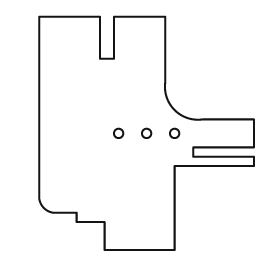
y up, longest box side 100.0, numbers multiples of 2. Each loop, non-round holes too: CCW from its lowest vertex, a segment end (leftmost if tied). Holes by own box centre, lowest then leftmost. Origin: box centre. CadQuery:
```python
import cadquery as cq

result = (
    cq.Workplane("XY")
    .moveTo(-18.0, -50.0)
    .lineTo(12.0, -50.0)
    .lineTo(12.0, -14.0)
    .lineTo(46.0, -14.0)
    .lineTo(46.0, -10.0)
    .lineTo(20.0, -10.0)
    .lineTo(20.0, -6.0)
    .lineTo(46.0, -6.0)
    .lineTo(46.0, 6.0)
    .lineTo(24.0, 6.0)
    .threePointArc((12.0, 10.0), (8.0, 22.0))
    .lineTo(8.0, 50.0)
    .lineTo(-14.0, 50.0)
    .lineTo(-14.0, 32.0)
    .lineTo(-20.0, 32.0)
    .lineTo(-20.0, 50.0)
    .lineTo(-46.0, 50.0)
    .lineTo(-46.0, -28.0)
    .threePointArc((-44.0, -32.0), (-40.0, -34.0))
    .lineTo(-30.0, -34.0)
    .lineTo(-30.0, -38.0)
    .lineTo(-18.0, -38.0)
    .close()
    .moveTo(-12.0, 0.0)
    .circle(2.0)
    .moveTo(0.0, 0.0)
    .circle(2.0)
    .moveTo(12.0, 0.0)
    .circle(2.0)
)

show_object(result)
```